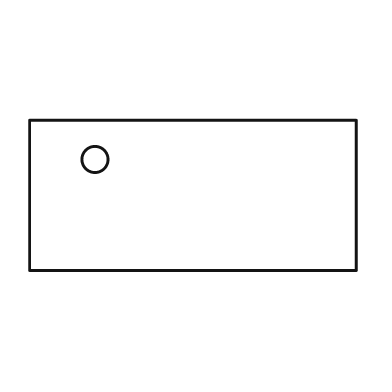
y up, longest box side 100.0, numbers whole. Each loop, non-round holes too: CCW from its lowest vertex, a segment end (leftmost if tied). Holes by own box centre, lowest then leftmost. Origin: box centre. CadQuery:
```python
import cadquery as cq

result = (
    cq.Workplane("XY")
    .moveTo(-50.0, -23.0)
    .lineTo(50.0, -23.0)
    .lineTo(50.0, 23.0)
    .lineTo(-50.0, 23.0)
    .close()
    .moveTo(-30.0, 11.0)
    .circle(4.0)
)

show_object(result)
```